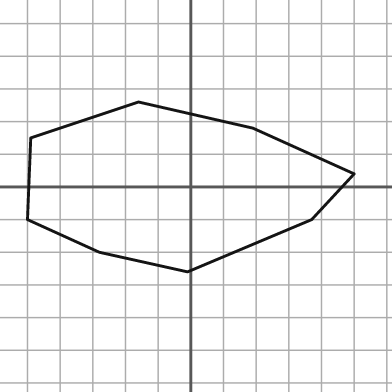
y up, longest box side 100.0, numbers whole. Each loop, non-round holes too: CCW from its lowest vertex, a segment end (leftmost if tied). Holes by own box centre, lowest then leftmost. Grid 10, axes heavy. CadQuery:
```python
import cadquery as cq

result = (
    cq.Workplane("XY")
    .moveTo(-1.0, -26.0)
    .lineTo(37.0, -10.0)
    .lineTo(50.0, 4.0)
    .lineTo(19.0, 18.0)
    .lineTo(-16.0, 26.0)
    .lineTo(-49.0, 15.0)
    .lineTo(-50.0, -10.0)
    .lineTo(-28.0, -20.0)
    .close()
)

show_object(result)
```